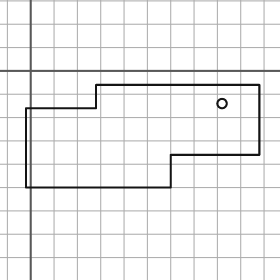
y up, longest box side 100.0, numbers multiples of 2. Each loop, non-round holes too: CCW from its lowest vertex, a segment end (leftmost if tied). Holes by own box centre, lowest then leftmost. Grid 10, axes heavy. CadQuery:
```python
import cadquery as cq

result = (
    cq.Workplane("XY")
    .moveTo(-2.0, -50.0)
    .lineTo(60.0, -50.0)
    .lineTo(60.0, -36.0)
    .lineTo(98.0, -36.0)
    .lineTo(98.0, -6.0)
    .lineTo(28.0, -6.0)
    .lineTo(28.0, -16.0)
    .lineTo(-2.0, -16.0)
    .close()
    .moveTo(82.0, -14.0)
    .circle(2.0)
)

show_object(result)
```